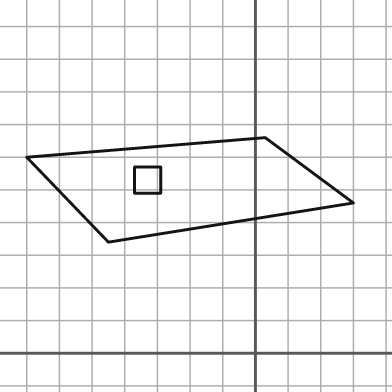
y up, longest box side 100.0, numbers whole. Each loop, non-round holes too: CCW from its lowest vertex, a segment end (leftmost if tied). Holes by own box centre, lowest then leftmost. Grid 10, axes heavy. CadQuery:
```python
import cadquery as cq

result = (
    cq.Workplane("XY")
    .moveTo(-45.0, 34.0)
    .lineTo(30.0, 46.0)
    .lineTo(3.0, 66.0)
    .lineTo(-70.0, 60.0)
    .close()
    .moveTo(-37.0, 49.0)
    .lineTo(-29.0, 49.0)
    .lineTo(-29.0, 57.0)
    .lineTo(-37.0, 57.0)
    .close()
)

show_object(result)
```